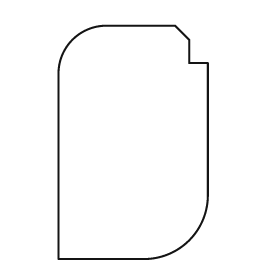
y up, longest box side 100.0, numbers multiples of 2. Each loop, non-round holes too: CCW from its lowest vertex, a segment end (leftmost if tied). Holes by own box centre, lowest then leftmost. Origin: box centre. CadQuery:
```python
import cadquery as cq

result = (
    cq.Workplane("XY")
    .moveTo(-32.0, -50.0)
    .lineTo(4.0, -50.0)
    .threePointArc((24.0, -42.0), (32.0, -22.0))
    .lineTo(32.0, 34.0)
    .lineTo(24.0, 34.0)
    .lineTo(24.0, 44.0)
    .lineTo(18.0, 50.0)
    .lineTo(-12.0, 50.0)
    .threePointArc((-26.0, 44.0), (-32.0, 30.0))
    .close()
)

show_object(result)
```